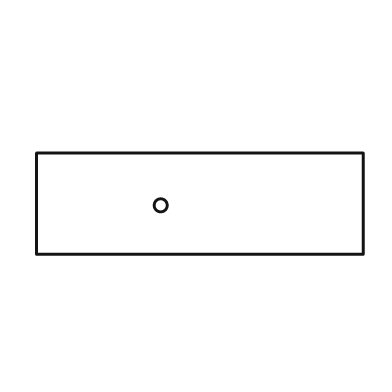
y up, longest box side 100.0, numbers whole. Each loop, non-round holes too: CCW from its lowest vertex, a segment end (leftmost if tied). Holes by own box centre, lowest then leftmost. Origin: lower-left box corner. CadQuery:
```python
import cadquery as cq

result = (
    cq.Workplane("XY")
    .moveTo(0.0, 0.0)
    .lineTo(100.0, 0.0)
    .lineTo(100.0, 31.0)
    .lineTo(0.0, 31.0)
    .close()
    .moveTo(38.0, 15.0)
    .circle(2.0)
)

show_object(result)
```